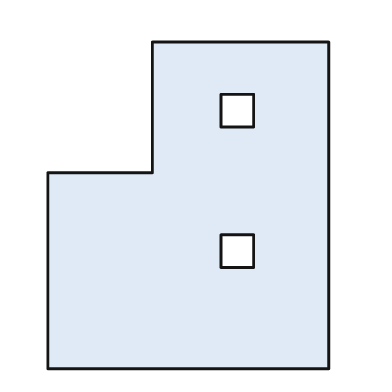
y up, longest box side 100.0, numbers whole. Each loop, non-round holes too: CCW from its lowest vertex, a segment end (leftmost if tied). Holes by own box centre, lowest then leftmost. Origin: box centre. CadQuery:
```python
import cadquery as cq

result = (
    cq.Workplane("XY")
    .moveTo(-43.0, -50.0)
    .lineTo(43.0, -50.0)
    .lineTo(43.0, 50.0)
    .lineTo(-11.0, 50.0)
    .lineTo(-11.0, 10.0)
    .lineTo(-43.0, 10.0)
    .close()
    .moveTo(10.0, -19.0)
    .lineTo(20.0, -19.0)
    .lineTo(20.0, -9.0)
    .lineTo(10.0, -9.0)
    .close()
    .moveTo(10.0, 24.0)
    .lineTo(20.0, 24.0)
    .lineTo(20.0, 34.0)
    .lineTo(10.0, 34.0)
    .close()
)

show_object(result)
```